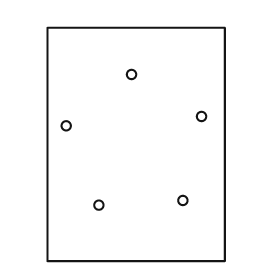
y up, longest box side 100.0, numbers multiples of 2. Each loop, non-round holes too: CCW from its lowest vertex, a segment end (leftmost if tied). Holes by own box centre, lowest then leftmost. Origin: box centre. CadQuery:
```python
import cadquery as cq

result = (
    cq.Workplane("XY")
    .moveTo(-38.0, -50.0)
    .lineTo(38.0, -50.0)
    .lineTo(38.0, 50.0)
    .lineTo(-38.0, 50.0)
    .close()
    .moveTo(-16.0, -26.0)
    .circle(2.0)
    .moveTo(20.0, -24.0)
    .circle(2.0)
    .moveTo(-30.0, 8.0)
    .circle(2.0)
    .moveTo(28.0, 12.0)
    .circle(2.0)
    .moveTo(-2.0, 30.0)
    .circle(2.0)
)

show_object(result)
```